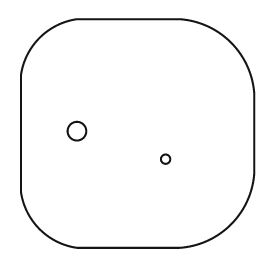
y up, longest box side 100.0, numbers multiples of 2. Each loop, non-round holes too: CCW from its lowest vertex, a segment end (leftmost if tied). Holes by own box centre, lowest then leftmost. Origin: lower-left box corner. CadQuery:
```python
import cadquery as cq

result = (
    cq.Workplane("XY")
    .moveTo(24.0, 0.0)
    .lineTo(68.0, 0.0)
    .threePointArc((90.0, 10.0), (100.0, 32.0))
    .lineTo(100.0, 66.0)
    .threePointArc((90.0, 88.0), (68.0, 98.0))
    .lineTo(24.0, 98.0)
    .threePointArc((8.0, 90.0), (0.0, 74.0))
    .lineTo(0.0, 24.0)
    .threePointArc((8.0, 8.0), (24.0, 0.0))
    .close()
    .moveTo(62.0, 38.0)
    .circle(2.0)
    .moveTo(24.0, 50.0)
    .circle(4.0)
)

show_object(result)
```